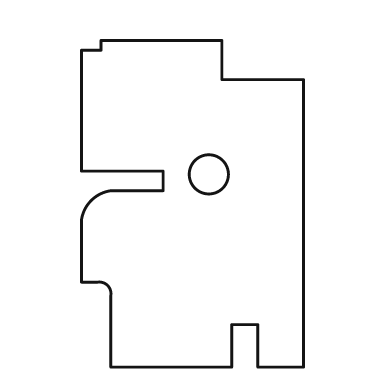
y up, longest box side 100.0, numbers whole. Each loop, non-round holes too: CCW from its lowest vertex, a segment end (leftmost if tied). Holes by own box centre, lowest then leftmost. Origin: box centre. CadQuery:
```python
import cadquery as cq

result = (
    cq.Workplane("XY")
    .moveTo(-25.0, -50.0)
    .lineTo(12.0, -50.0)
    .lineTo(12.0, -37.0)
    .lineTo(20.0, -37.0)
    .lineTo(20.0, -50.0)
    .lineTo(34.0, -50.0)
    .lineTo(34.0, 38.0)
    .lineTo(9.0, 38.0)
    .lineTo(9.0, 50.0)
    .lineTo(-28.0, 50.0)
    .lineTo(-28.0, 47.0)
    .lineTo(-34.0, 47.0)
    .lineTo(-34.0, 10.0)
    .lineTo(-9.0, 10.0)
    .lineTo(-9.0, 4.0)
    .lineTo(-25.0, 4.0)
    .threePointArc((-31.0, 1.0), (-34.0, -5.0))
    .lineTo(-34.0, -24.0)
    .lineTo(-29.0, -24.0)
    .threePointArc((-26.0, -25.0), (-25.0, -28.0))
    .close()
    .moveTo(5.0, 9.0)
    .circle(6.0)
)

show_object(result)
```